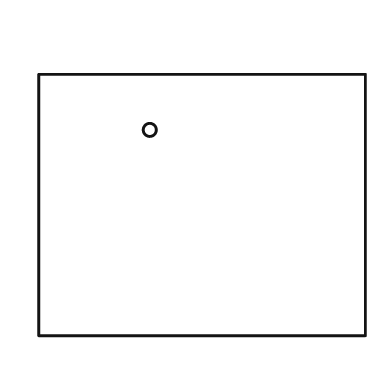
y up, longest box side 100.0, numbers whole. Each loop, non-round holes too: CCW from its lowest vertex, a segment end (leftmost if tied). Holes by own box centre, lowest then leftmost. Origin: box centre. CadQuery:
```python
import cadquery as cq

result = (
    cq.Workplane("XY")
    .moveTo(-50.0, -40.0)
    .lineTo(50.0, -40.0)
    .lineTo(50.0, 40.0)
    .lineTo(-50.0, 40.0)
    .close()
    .moveTo(-16.0, 23.0)
    .circle(2.0)
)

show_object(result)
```